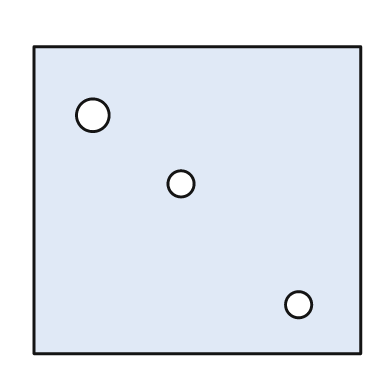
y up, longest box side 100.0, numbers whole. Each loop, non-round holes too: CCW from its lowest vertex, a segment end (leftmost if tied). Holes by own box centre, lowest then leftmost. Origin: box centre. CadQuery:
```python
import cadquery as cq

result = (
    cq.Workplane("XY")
    .moveTo(-50.0, -47.0)
    .lineTo(50.0, -47.0)
    .lineTo(50.0, 47.0)
    .lineTo(-50.0, 47.0)
    .close()
    .moveTo(31.0, -32.0)
    .circle(4.0)
    .moveTo(-5.0, 5.0)
    .circle(4.0)
    .moveTo(-32.0, 26.0)
    .circle(5.0)
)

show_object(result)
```